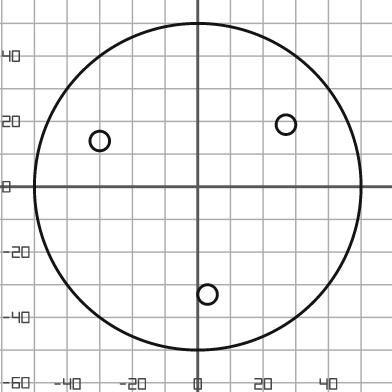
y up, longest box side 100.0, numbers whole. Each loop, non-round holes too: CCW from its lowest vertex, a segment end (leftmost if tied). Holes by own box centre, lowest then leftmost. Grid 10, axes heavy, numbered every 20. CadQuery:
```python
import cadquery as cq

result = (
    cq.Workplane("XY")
    .moveTo(0.0, 0.0)
    .circle(50.0)
    .moveTo(3.0, -33.0)
    .circle(3.0)
    .moveTo(-30.0, 14.0)
    .circle(3.0)
    .moveTo(27.0, 19.0)
    .circle(3.0)
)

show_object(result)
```